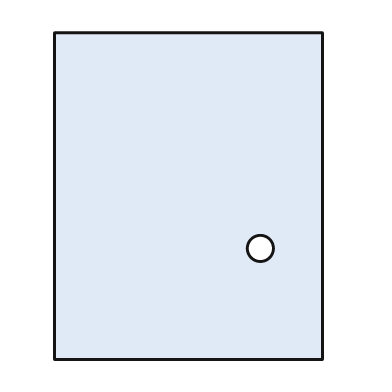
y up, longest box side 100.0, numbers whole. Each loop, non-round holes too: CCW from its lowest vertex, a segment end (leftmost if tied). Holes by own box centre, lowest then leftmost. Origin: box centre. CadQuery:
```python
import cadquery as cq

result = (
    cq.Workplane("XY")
    .moveTo(-41.0, -50.0)
    .lineTo(41.0, -50.0)
    .lineTo(41.0, 50.0)
    .lineTo(-41.0, 50.0)
    .close()
    .moveTo(22.0, -16.0)
    .circle(4.0)
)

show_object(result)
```